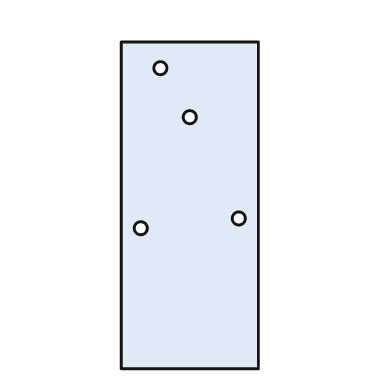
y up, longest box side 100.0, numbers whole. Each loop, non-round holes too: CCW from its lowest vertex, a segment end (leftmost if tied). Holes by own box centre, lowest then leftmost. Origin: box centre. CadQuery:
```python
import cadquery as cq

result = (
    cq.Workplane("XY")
    .moveTo(-21.0, -50.0)
    .lineTo(21.0, -50.0)
    .lineTo(21.0, 50.0)
    .lineTo(-21.0, 50.0)
    .close()
    .moveTo(-15.0, -7.0)
    .circle(2.0)
    .moveTo(15.0, -4.0)
    .circle(2.0)
    .moveTo(0.0, 27.0)
    .circle(2.0)
    .moveTo(-9.0, 42.0)
    .circle(2.0)
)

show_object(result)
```